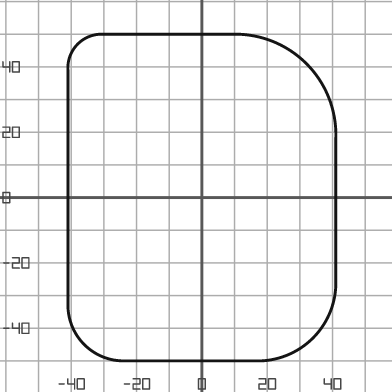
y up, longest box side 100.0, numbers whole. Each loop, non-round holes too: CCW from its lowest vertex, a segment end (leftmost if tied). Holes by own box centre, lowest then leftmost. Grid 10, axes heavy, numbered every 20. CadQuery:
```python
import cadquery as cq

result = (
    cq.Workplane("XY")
    .moveTo(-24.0, -50.0)
    .lineTo(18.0, -50.0)
    .threePointArc((34.0, -43.0), (41.0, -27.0))
    .lineTo(41.0, 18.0)
    .threePointArc((32.0, 41.0), (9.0, 50.0))
    .lineTo(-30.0, 50.0)
    .threePointArc((-38.0, 47.0), (-41.0, 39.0))
    .lineTo(-41.0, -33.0)
    .threePointArc((-36.0, -45.0), (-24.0, -50.0))
    .close()
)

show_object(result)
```